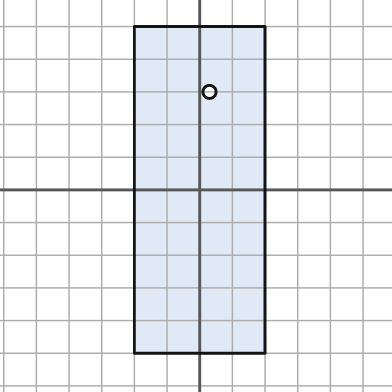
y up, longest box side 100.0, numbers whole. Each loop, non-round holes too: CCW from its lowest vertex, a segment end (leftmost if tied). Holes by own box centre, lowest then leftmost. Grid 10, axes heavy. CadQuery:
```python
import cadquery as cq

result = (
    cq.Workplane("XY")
    .moveTo(-20.0, -50.0)
    .lineTo(20.0, -50.0)
    .lineTo(20.0, 50.0)
    .lineTo(-20.0, 50.0)
    .close()
    .moveTo(3.0, 30.0)
    .circle(2.0)
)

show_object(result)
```